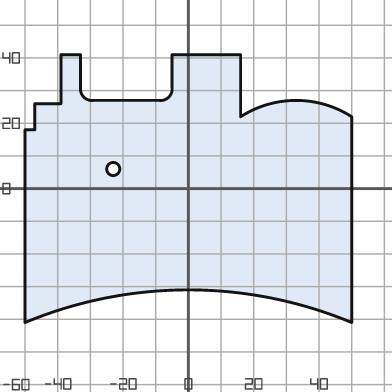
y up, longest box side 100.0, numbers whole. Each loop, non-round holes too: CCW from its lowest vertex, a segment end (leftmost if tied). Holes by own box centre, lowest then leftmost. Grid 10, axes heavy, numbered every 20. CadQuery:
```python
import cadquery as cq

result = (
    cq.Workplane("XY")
    .moveTo(-50.0, -41.0)
    .threePointArc((0.0, -31.0), (50.0, -41.0))
    .lineTo(50.0, 22.0)
    .threePointArc((33.0, 27.0), (16.0, 22.0))
    .lineTo(16.0, 41.0)
    .lineTo(-5.0, 41.0)
    .lineTo(-5.0, 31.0)
    .threePointArc((-6.0, 28.0), (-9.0, 27.0))
    .lineTo(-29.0, 27.0)
    .threePointArc((-32.0, 28.0), (-33.0, 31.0))
    .lineTo(-33.0, 41.0)
    .lineTo(-39.0, 41.0)
    .lineTo(-39.0, 26.0)
    .lineTo(-47.0, 26.0)
    .lineTo(-47.0, 18.0)
    .lineTo(-50.0, 18.0)
    .close()
    .moveTo(-23.0, 6.0)
    .circle(2.0)
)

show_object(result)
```